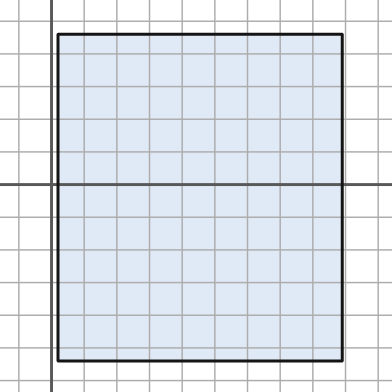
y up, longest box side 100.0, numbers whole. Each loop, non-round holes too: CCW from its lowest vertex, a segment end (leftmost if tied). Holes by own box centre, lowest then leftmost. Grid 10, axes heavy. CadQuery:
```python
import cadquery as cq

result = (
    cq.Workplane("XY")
    .moveTo(2.0, -54.0)
    .lineTo(89.0, -54.0)
    .lineTo(89.0, 46.0)
    .lineTo(2.0, 46.0)
    .close()
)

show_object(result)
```